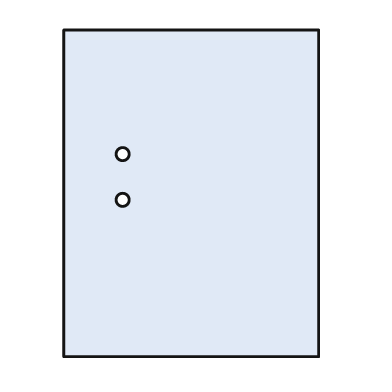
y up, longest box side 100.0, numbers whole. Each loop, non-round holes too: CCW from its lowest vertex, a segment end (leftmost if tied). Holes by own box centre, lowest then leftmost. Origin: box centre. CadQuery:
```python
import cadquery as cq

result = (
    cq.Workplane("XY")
    .moveTo(-39.0, -50.0)
    .lineTo(39.0, -50.0)
    .lineTo(39.0, 50.0)
    .lineTo(-39.0, 50.0)
    .close()
    .moveTo(-21.0, -2.0)
    .circle(2.0)
    .moveTo(-21.0, 12.0)
    .circle(2.0)
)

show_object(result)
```